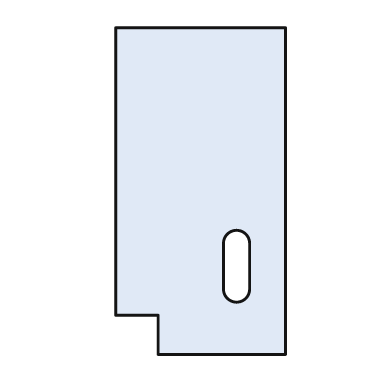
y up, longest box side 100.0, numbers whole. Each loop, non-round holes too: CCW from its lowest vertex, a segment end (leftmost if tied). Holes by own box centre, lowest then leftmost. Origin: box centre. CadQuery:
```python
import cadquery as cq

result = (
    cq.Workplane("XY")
    .moveTo(-13.0, -50.0)
    .lineTo(26.0, -50.0)
    .lineTo(26.0, 50.0)
    .lineTo(-26.0, 50.0)
    .lineTo(-26.0, -38.0)
    .lineTo(-13.0, -38.0)
    .close()
    .moveTo(7.0, -30.0)
    .threePointArc((11.0, -34.0), (15.0, -30.0))
    .lineTo(15.0, -16.0)
    .threePointArc((11.0, -12.0), (7.0, -16.0))
    .close()
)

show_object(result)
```